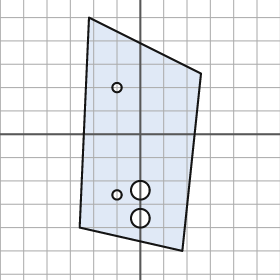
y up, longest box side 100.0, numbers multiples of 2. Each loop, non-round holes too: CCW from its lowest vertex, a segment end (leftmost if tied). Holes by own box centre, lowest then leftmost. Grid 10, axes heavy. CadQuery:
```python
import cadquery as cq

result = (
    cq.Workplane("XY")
    .moveTo(18.0, -50.0)
    .lineTo(26.0, 26.0)
    .lineTo(-22.0, 50.0)
    .lineTo(-26.0, -40.0)
    .close()
    .moveTo(0.0, -36.0)
    .circle(4.0)
    .moveTo(-10.0, -26.0)
    .circle(2.0)
    .moveTo(0.0, -24.0)
    .circle(4.0)
    .moveTo(-10.0, 20.0)
    .circle(2.0)
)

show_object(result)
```